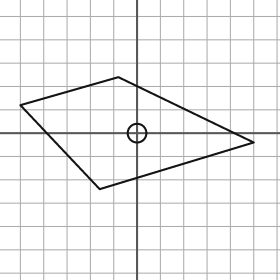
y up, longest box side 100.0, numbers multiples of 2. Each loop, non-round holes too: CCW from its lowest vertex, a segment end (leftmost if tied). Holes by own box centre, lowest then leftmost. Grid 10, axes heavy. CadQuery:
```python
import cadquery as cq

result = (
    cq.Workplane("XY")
    .moveTo(-16.0, -24.0)
    .lineTo(50.0, -4.0)
    .lineTo(-8.0, 24.0)
    .lineTo(-50.0, 12.0)
    .close()
    .moveTo(0.0, 0.0)
    .circle(4.0)
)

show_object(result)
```